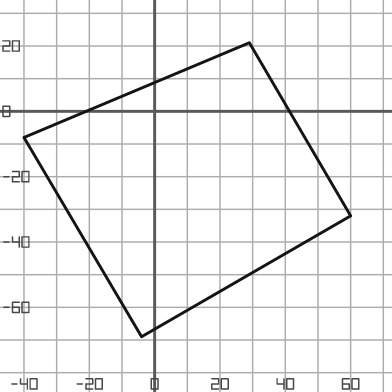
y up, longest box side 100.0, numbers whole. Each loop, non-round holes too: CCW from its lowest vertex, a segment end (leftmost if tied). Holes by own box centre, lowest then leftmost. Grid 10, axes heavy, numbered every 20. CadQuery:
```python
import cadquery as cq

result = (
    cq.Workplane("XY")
    .moveTo(-4.0, -69.0)
    .lineTo(60.0, -32.0)
    .lineTo(29.0, 21.0)
    .lineTo(-40.0, -8.0)
    .close()
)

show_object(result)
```